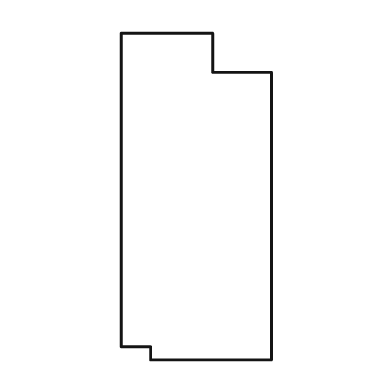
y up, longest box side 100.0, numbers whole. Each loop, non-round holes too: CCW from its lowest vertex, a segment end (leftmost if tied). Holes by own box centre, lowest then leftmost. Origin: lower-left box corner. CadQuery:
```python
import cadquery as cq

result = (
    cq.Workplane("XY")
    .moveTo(9.0, 0.0)
    .lineTo(46.0, 0.0)
    .lineTo(46.0, 88.0)
    .lineTo(28.0, 88.0)
    .lineTo(28.0, 100.0)
    .lineTo(0.0, 100.0)
    .lineTo(0.0, 4.0)
    .lineTo(9.0, 4.0)
    .close()
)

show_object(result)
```